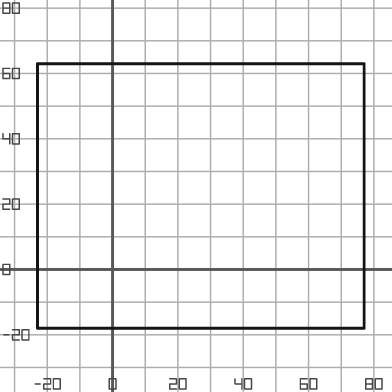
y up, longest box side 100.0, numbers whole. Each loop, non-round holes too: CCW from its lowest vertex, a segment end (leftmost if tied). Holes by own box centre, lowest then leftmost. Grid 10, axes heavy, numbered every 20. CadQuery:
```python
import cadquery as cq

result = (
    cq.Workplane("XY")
    .moveTo(-23.0, -18.0)
    .lineTo(77.0, -18.0)
    .lineTo(77.0, 63.0)
    .lineTo(-23.0, 63.0)
    .close()
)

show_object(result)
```